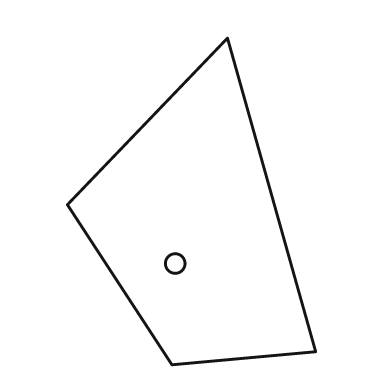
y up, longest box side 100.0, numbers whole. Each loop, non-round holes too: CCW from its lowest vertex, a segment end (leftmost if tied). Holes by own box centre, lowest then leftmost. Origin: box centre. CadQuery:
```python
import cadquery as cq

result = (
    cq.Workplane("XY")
    .moveTo(-6.0, -50.0)
    .lineTo(38.0, -46.0)
    .lineTo(11.0, 50.0)
    .lineTo(-38.0, -1.0)
    .close()
    .moveTo(-5.0, -19.0)
    .circle(3.0)
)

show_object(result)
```